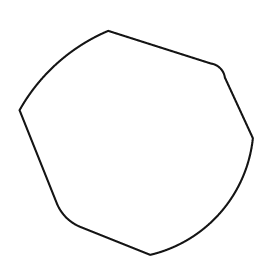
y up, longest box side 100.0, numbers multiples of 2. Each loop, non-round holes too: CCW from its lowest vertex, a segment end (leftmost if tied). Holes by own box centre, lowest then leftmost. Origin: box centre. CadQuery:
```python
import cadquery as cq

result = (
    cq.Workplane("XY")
    .moveTo(6.0, -48.0)
    .threePointArc((36.0, -30.0), (50.0, 2.0))
    .lineTo(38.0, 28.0)
    .threePointArc((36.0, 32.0), (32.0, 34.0))
    .lineTo(-12.0, 48.0)
    .threePointArc((-34.0, 34.0), (-50.0, 14.0))
    .lineTo(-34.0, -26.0)
    .threePointArc((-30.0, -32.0), (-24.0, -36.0))
    .close()
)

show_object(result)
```